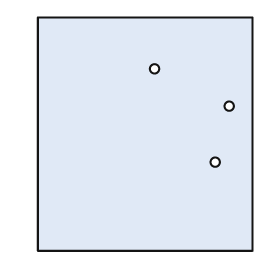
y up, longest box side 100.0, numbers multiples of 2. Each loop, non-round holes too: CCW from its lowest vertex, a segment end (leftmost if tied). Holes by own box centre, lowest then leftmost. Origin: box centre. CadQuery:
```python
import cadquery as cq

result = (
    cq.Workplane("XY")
    .moveTo(-46.0, -50.0)
    .lineTo(46.0, -50.0)
    .lineTo(46.0, 50.0)
    .lineTo(-46.0, 50.0)
    .close()
    .moveTo(30.0, -12.0)
    .circle(2.0)
    .moveTo(36.0, 12.0)
    .circle(2.0)
    .moveTo(4.0, 28.0)
    .circle(2.0)
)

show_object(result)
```